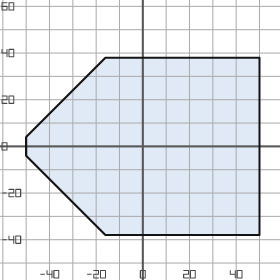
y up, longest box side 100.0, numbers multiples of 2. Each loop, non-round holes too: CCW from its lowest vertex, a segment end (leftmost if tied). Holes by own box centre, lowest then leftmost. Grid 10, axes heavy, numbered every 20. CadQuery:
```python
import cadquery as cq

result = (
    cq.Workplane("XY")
    .moveTo(-16.0, -38.0)
    .lineTo(50.0, -38.0)
    .lineTo(50.0, 38.0)
    .lineTo(-16.0, 38.0)
    .lineTo(-50.0, 4.0)
    .lineTo(-50.0, -4.0)
    .close()
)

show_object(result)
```